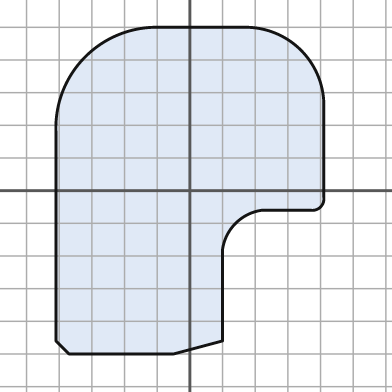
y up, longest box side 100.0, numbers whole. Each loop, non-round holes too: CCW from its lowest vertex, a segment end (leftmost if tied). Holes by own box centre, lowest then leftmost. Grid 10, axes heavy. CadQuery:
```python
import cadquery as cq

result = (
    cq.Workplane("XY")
    .moveTo(-37.0, -50.0)
    .lineTo(-5.0, -50.0)
    .lineTo(10.0, -46.0)
    .lineTo(10.0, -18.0)
    .threePointArc((14.0, -10.0), (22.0, -6.0))
    .lineTo(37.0, -6.0)
    .threePointArc((40.0, -5.0), (41.0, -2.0))
    .lineTo(41.0, 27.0)
    .threePointArc((34.0, 43.0), (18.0, 50.0))
    .lineTo(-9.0, 50.0)
    .threePointArc((-32.0, 41.0), (-41.0, 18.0))
    .lineTo(-41.0, -46.0)
    .close()
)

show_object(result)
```